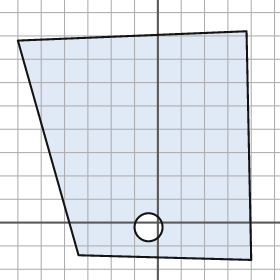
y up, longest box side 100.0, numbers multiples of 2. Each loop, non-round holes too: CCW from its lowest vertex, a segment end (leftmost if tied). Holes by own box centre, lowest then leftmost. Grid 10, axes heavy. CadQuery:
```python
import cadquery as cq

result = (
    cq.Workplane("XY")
    .moveTo(40.0, -16.0)
    .lineTo(38.0, 82.0)
    .lineTo(-60.0, 78.0)
    .lineTo(-34.0, -14.0)
    .close()
    .moveTo(-4.0, -2.0)
    .circle(6.0)
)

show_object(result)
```